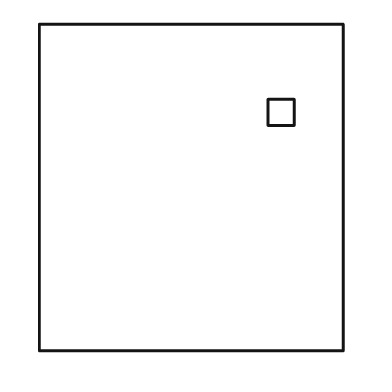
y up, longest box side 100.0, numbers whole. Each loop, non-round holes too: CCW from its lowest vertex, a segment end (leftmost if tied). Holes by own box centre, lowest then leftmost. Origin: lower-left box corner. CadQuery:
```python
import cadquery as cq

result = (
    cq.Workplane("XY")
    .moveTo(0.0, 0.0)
    .lineTo(93.0, 0.0)
    .lineTo(93.0, 100.0)
    .lineTo(0.0, 100.0)
    .close()
    .moveTo(70.0, 69.0)
    .lineTo(78.0, 69.0)
    .lineTo(78.0, 77.0)
    .lineTo(70.0, 77.0)
    .close()
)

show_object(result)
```